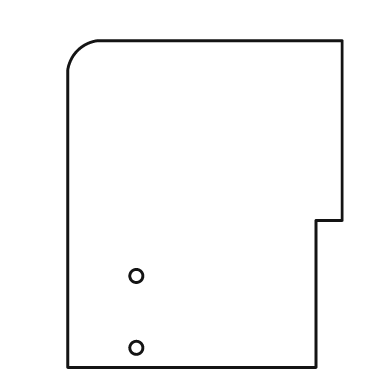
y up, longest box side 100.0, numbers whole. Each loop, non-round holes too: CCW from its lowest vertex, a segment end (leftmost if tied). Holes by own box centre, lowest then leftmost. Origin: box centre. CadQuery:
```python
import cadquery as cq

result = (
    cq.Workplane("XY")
    .moveTo(-42.0, -50.0)
    .lineTo(34.0, -50.0)
    .lineTo(34.0, -5.0)
    .lineTo(42.0, -5.0)
    .lineTo(42.0, 50.0)
    .lineTo(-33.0, 50.0)
    .threePointArc((-39.0, 47.0), (-42.0, 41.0))
    .close()
    .moveTo(-21.0, -44.0)
    .circle(2.0)
    .moveTo(-21.0, -22.0)
    .circle(2.0)
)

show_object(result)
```